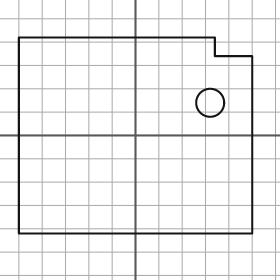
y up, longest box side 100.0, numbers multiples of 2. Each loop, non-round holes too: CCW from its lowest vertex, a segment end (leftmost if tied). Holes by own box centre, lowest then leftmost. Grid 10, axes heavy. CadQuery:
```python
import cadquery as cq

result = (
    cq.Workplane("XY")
    .moveTo(-50.0, -42.0)
    .lineTo(50.0, -42.0)
    .lineTo(50.0, 34.0)
    .lineTo(34.0, 34.0)
    .lineTo(34.0, 42.0)
    .lineTo(-50.0, 42.0)
    .close()
    .moveTo(32.0, 14.0)
    .circle(6.0)
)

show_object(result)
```